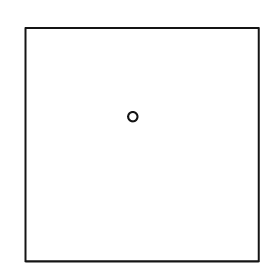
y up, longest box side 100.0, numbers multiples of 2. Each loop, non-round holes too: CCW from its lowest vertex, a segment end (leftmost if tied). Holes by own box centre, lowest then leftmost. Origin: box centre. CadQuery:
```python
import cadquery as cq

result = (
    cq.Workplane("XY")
    .moveTo(-50.0, -50.0)
    .lineTo(50.0, -50.0)
    .lineTo(50.0, 50.0)
    .lineTo(-50.0, 50.0)
    .close()
    .moveTo(-4.0, 12.0)
    .circle(2.0)
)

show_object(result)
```